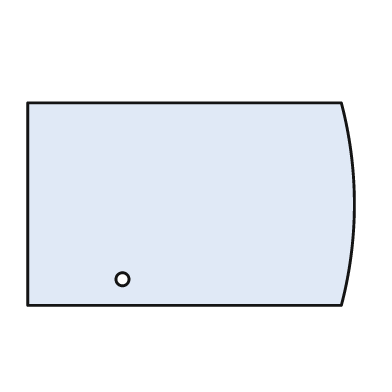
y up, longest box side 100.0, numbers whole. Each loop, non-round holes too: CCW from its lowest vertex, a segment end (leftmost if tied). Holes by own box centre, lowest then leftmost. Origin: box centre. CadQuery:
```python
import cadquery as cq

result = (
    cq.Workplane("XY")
    .moveTo(-50.0, -31.0)
    .lineTo(46.0, -31.0)
    .threePointArc((50.0, 0.0), (46.0, 31.0))
    .lineTo(-50.0, 31.0)
    .close()
    .moveTo(-21.0, -23.0)
    .circle(2.0)
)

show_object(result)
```